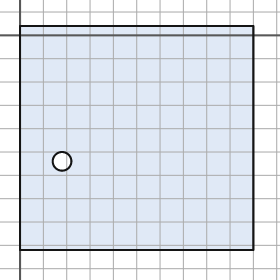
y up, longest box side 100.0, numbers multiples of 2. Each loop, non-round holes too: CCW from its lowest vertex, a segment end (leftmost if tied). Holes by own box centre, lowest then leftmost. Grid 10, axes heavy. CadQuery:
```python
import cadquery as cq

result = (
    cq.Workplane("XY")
    .moveTo(0.0, -92.0)
    .lineTo(100.0, -92.0)
    .lineTo(100.0, 4.0)
    .lineTo(0.0, 4.0)
    .close()
    .moveTo(18.0, -54.0)
    .circle(4.0)
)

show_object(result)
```